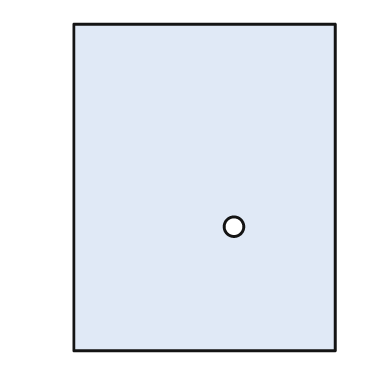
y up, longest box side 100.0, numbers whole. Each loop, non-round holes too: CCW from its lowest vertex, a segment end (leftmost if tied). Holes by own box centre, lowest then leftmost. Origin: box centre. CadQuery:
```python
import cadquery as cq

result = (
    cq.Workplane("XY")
    .moveTo(-40.0, -50.0)
    .lineTo(40.0, -50.0)
    .lineTo(40.0, 50.0)
    .lineTo(-40.0, 50.0)
    .close()
    .moveTo(9.0, -12.0)
    .circle(3.0)
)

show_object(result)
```